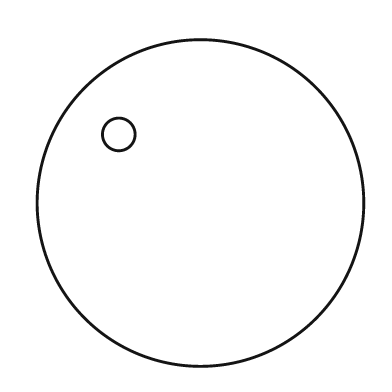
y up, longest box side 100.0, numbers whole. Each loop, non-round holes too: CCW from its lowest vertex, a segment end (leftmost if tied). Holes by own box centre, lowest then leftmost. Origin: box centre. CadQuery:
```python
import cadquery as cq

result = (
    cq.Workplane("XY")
    .moveTo(0.0, 0.0)
    .circle(50.0)
    .moveTo(-25.0, 21.0)
    .circle(5.0)
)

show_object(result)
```